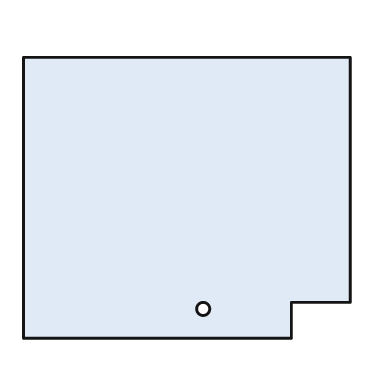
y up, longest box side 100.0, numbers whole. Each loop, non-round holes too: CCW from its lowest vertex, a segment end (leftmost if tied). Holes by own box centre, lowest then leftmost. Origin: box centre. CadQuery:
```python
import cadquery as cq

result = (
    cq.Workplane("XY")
    .moveTo(-50.0, -43.0)
    .lineTo(32.0, -43.0)
    .lineTo(32.0, -32.0)
    .lineTo(50.0, -32.0)
    .lineTo(50.0, 43.0)
    .lineTo(-50.0, 43.0)
    .close()
    .moveTo(5.0, -34.0)
    .circle(2.0)
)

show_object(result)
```